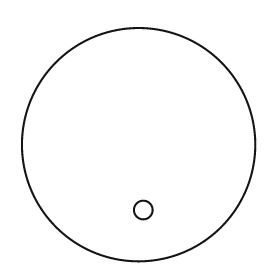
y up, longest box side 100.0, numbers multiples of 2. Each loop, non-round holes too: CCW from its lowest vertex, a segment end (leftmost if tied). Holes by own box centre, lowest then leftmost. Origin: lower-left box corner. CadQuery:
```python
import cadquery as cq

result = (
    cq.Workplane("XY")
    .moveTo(50.0, 50.0)
    .circle(50.0)
    .moveTo(52.0, 22.0)
    .circle(4.0)
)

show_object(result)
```